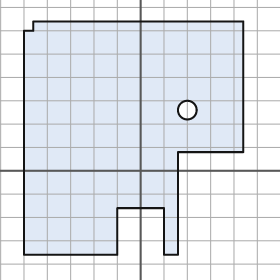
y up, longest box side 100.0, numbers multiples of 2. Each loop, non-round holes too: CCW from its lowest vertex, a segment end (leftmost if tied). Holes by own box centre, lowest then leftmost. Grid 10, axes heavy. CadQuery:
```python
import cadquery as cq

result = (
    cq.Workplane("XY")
    .moveTo(-50.0, -36.0)
    .lineTo(-10.0, -36.0)
    .lineTo(-10.0, -16.0)
    .lineTo(10.0, -16.0)
    .lineTo(10.0, -36.0)
    .lineTo(16.0, -36.0)
    .lineTo(16.0, 8.0)
    .lineTo(44.0, 8.0)
    .lineTo(44.0, 64.0)
    .lineTo(-46.0, 64.0)
    .lineTo(-46.0, 60.0)
    .lineTo(-50.0, 60.0)
    .close()
    .moveTo(20.0, 26.0)
    .circle(4.0)
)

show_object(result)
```